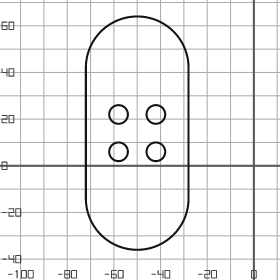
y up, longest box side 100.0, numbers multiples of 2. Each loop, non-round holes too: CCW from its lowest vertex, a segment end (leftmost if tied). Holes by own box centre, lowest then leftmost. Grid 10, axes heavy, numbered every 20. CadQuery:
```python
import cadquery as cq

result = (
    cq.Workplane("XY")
    .moveTo(-72.0, -14.0)
    .threePointArc((-50.0, -36.0), (-28.0, -14.0))
    .lineTo(-28.0, 42.0)
    .threePointArc((-50.0, 64.0), (-72.0, 42.0))
    .close()
    .moveTo(-58.0, 6.0)
    .circle(4.0)
    .moveTo(-42.0, 6.0)
    .circle(4.0)
    .moveTo(-58.0, 22.0)
    .circle(4.0)
    .moveTo(-42.0, 22.0)
    .circle(4.0)
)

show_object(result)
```